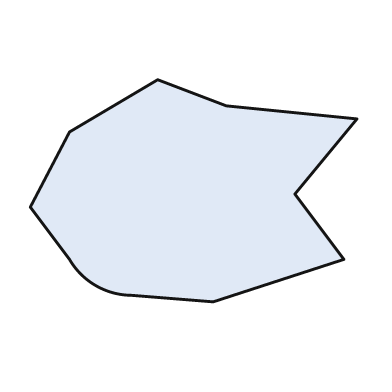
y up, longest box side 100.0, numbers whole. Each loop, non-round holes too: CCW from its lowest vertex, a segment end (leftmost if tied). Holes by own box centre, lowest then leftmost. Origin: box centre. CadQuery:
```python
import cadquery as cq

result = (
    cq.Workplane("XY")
    .moveTo(6.0, -34.0)
    .lineTo(46.0, -21.0)
    .lineTo(31.0, -1.0)
    .lineTo(50.0, 22.0)
    .lineTo(10.0, 26.0)
    .lineTo(-11.0, 34.0)
    .lineTo(-38.0, 18.0)
    .lineTo(-50.0, -5.0)
    .lineTo(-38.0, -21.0)
    .threePointArc((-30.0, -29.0), (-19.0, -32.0))
    .close()
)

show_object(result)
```